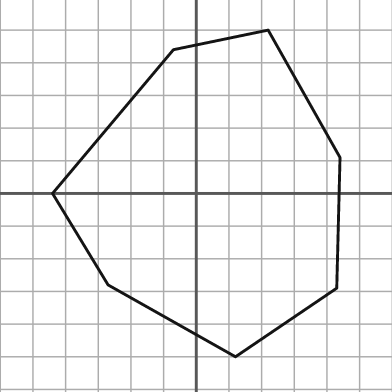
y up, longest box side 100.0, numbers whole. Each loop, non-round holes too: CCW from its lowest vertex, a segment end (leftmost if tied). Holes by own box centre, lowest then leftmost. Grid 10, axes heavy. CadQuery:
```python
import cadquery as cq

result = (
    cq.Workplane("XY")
    .moveTo(12.0, -50.0)
    .lineTo(43.0, -29.0)
    .lineTo(44.0, 11.0)
    .lineTo(22.0, 50.0)
    .lineTo(-7.0, 44.0)
    .lineTo(-44.0, 0.0)
    .lineTo(-27.0, -28.0)
    .close()
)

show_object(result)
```